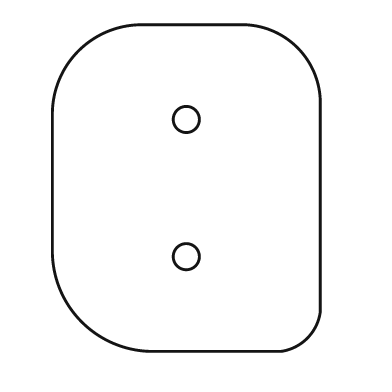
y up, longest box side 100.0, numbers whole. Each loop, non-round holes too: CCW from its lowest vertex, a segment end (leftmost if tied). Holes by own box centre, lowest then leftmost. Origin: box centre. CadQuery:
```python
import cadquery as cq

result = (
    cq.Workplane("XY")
    .moveTo(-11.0, -50.0)
    .lineTo(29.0, -50.0)
    .threePointArc((37.0, -46.0), (41.0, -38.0))
    .lineTo(41.0, 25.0)
    .threePointArc((34.0, 43.0), (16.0, 50.0))
    .lineTo(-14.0, 50.0)
    .threePointArc((-33.0, 42.0), (-41.0, 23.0))
    .lineTo(-41.0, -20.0)
    .threePointArc((-32.0, -41.0), (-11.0, -50.0))
    .close()
    .moveTo(0.0, -21.0)
    .circle(4.0)
    .moveTo(0.0, 21.0)
    .circle(4.0)
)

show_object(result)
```